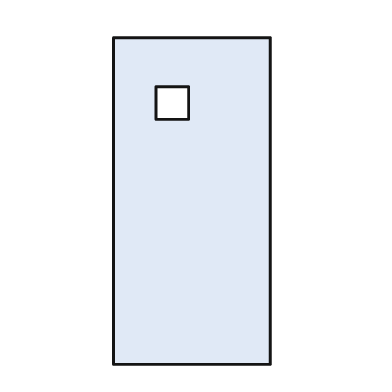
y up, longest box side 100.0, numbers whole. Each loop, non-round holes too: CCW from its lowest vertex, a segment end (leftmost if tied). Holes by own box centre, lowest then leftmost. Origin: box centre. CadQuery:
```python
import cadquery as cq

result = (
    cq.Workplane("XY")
    .moveTo(-24.0, -50.0)
    .lineTo(24.0, -50.0)
    .lineTo(24.0, 50.0)
    .lineTo(-24.0, 50.0)
    .close()
    .moveTo(-11.0, 25.0)
    .lineTo(-1.0, 25.0)
    .lineTo(-1.0, 35.0)
    .lineTo(-11.0, 35.0)
    .close()
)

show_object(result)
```